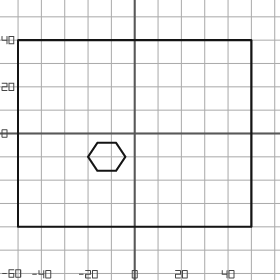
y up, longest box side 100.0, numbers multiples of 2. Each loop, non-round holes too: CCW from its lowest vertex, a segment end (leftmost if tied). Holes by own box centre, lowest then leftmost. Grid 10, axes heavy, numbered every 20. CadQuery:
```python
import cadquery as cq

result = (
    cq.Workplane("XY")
    .moveTo(-50.0, -40.0)
    .lineTo(50.0, -40.0)
    .lineTo(50.0, 40.0)
    .lineTo(-50.0, 40.0)
    .close()
    .moveTo(-16.0, -16.0)
    .lineTo(-8.0, -16.0)
    .lineTo(-4.0, -10.0)
    .lineTo(-8.0, -4.0)
    .lineTo(-16.0, -4.0)
    .lineTo(-20.0, -10.0)
    .close()
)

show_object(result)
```